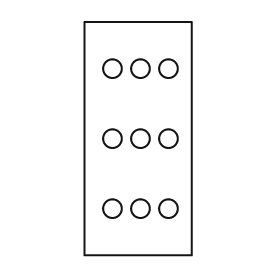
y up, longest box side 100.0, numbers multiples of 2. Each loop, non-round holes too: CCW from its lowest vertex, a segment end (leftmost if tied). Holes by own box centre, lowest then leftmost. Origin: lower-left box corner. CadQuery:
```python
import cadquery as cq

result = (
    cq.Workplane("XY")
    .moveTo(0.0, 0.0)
    .lineTo(46.0, 0.0)
    .lineTo(46.0, 100.0)
    .lineTo(0.0, 100.0)
    .close()
    .moveTo(12.0, 20.0)
    .circle(4.0)
    .moveTo(24.0, 20.0)
    .circle(4.0)
    .moveTo(36.0, 20.0)
    .circle(4.0)
    .moveTo(12.0, 50.0)
    .circle(4.0)
    .moveTo(24.0, 50.0)
    .circle(4.0)
    .moveTo(36.0, 50.0)
    .circle(4.0)
    .moveTo(12.0, 80.0)
    .circle(4.0)
    .moveTo(24.0, 80.0)
    .circle(4.0)
    .moveTo(36.0, 80.0)
    .circle(4.0)
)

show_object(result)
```